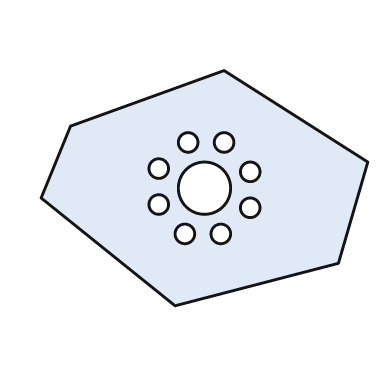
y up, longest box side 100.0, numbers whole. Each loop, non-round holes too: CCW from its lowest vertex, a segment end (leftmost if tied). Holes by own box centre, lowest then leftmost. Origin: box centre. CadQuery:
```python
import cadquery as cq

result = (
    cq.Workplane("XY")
    .moveTo(-9.0, -36.0)
    .lineTo(41.0, -23.0)
    .lineTo(50.0, 8.0)
    .lineTo(6.0, 36.0)
    .lineTo(-41.0, 19.0)
    .lineTo(-50.0, -3.0)
    .close()
    .moveTo(-6.0, -14.0)
    .circle(3.0)
    .moveTo(5.0, -14.0)
    .circle(3.0)
    .moveTo(14.0, -6.0)
    .circle(3.0)
    .moveTo(-14.0, -5.0)
    .circle(3.0)
    .moveTo(0.0, 0.0)
    .circle(8.0)
    .moveTo(14.0, 5.0)
    .circle(3.0)
    .moveTo(-14.0, 6.0)
    .circle(3.0)
    .moveTo(-5.0, 14.0)
    .circle(3.0)
    .moveTo(6.0, 14.0)
    .circle(3.0)
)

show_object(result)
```